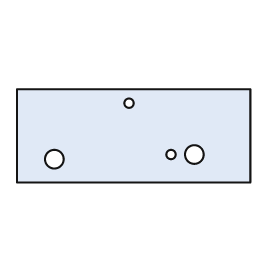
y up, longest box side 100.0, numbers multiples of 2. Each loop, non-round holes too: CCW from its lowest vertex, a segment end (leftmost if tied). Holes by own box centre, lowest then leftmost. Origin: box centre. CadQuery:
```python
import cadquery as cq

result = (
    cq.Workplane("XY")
    .moveTo(-50.0, -20.0)
    .lineTo(50.0, -20.0)
    .lineTo(50.0, 20.0)
    .lineTo(-50.0, 20.0)
    .close()
    .moveTo(-34.0, -10.0)
    .circle(4.0)
    .moveTo(16.0, -8.0)
    .circle(2.0)
    .moveTo(26.0, -8.0)
    .circle(4.0)
    .moveTo(-2.0, 14.0)
    .circle(2.0)
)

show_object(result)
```